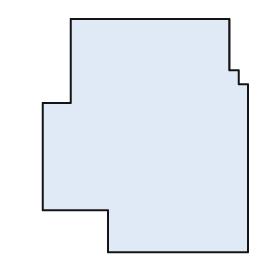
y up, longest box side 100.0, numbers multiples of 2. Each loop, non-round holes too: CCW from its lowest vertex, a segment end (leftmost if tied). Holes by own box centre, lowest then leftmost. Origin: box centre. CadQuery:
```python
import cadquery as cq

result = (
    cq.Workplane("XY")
    .moveTo(-16.0, -50.0)
    .lineTo(44.0, -50.0)
    .lineTo(44.0, 22.0)
    .lineTo(40.0, 22.0)
    .lineTo(40.0, 28.0)
    .lineTo(36.0, 28.0)
    .lineTo(36.0, 50.0)
    .lineTo(-32.0, 50.0)
    .lineTo(-32.0, 14.0)
    .lineTo(-44.0, 14.0)
    .lineTo(-44.0, -32.0)
    .lineTo(-16.0, -32.0)
    .close()
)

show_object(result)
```